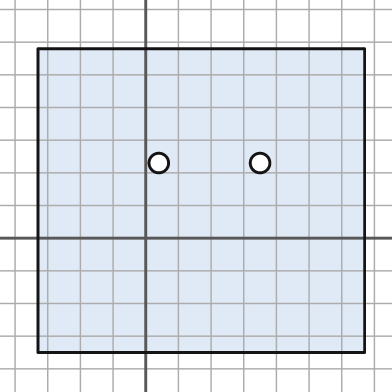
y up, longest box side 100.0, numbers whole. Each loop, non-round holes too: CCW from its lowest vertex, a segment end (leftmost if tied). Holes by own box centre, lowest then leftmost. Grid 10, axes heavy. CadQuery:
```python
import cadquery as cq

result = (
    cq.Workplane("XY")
    .moveTo(-33.0, -35.0)
    .lineTo(67.0, -35.0)
    .lineTo(67.0, 58.0)
    .lineTo(-33.0, 58.0)
    .close()
    .moveTo(4.0, 23.0)
    .circle(3.0)
    .moveTo(35.0, 23.0)
    .circle(3.0)
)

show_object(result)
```